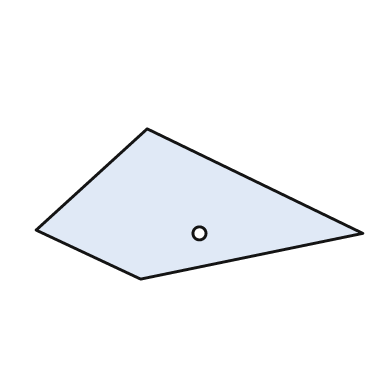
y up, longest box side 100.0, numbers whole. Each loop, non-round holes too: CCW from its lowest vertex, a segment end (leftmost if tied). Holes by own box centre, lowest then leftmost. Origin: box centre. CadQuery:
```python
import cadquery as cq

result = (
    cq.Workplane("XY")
    .moveTo(-18.0, -23.0)
    .lineTo(50.0, -9.0)
    .lineTo(-16.0, 23.0)
    .lineTo(-50.0, -8.0)
    .close()
    .moveTo(0.0, -9.0)
    .circle(2.0)
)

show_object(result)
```